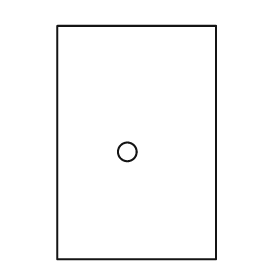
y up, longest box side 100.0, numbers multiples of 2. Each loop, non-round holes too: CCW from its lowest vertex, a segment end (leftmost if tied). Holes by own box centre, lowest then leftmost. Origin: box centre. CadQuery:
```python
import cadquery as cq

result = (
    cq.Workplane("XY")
    .moveTo(-34.0, -50.0)
    .lineTo(34.0, -50.0)
    .lineTo(34.0, 50.0)
    .lineTo(-34.0, 50.0)
    .close()
    .moveTo(-4.0, -4.0)
    .circle(4.0)
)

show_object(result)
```